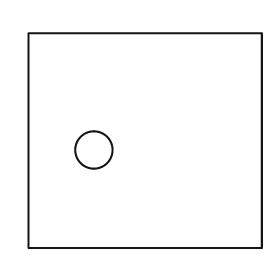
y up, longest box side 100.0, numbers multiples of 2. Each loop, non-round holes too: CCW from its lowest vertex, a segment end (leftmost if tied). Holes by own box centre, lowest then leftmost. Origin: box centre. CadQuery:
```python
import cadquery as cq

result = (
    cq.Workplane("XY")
    .moveTo(-50.0, -46.0)
    .lineTo(50.0, -46.0)
    .lineTo(50.0, 46.0)
    .lineTo(-50.0, 46.0)
    .close()
    .moveTo(-22.0, -4.0)
    .circle(8.0)
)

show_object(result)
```